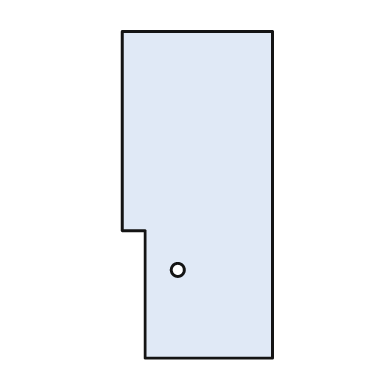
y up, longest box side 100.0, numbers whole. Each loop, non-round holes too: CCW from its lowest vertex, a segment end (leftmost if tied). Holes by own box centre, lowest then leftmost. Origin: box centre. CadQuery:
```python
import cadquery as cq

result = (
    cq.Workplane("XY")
    .moveTo(-16.0, -50.0)
    .lineTo(23.0, -50.0)
    .lineTo(23.0, 50.0)
    .lineTo(-23.0, 50.0)
    .lineTo(-23.0, -11.0)
    .lineTo(-16.0, -11.0)
    .close()
    .moveTo(-6.0, -23.0)
    .circle(2.0)
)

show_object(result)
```